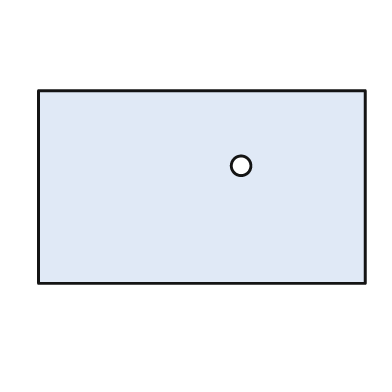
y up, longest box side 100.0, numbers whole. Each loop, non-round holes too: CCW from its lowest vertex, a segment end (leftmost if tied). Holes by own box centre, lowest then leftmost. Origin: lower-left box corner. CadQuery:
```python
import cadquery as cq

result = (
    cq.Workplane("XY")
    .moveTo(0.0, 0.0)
    .lineTo(100.0, 0.0)
    .lineTo(100.0, 59.0)
    .lineTo(0.0, 59.0)
    .close()
    .moveTo(62.0, 36.0)
    .circle(3.0)
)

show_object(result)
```